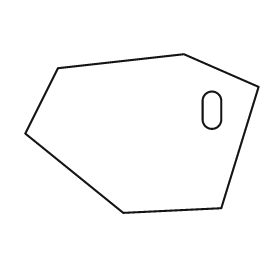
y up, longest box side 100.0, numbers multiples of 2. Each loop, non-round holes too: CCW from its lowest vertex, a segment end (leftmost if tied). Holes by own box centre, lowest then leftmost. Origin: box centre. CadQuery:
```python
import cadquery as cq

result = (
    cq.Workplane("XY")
    .moveTo(-8.0, -34.0)
    .lineTo(34.0, -32.0)
    .lineTo(50.0, 20.0)
    .lineTo(18.0, 34.0)
    .lineTo(-36.0, 28.0)
    .lineTo(-50.0, 0.0)
    .close()
    .moveTo(26.0, 6.0)
    .threePointArc((30.0, 2.0), (34.0, 6.0))
    .lineTo(34.0, 14.0)
    .threePointArc((30.0, 18.0), (26.0, 14.0))
    .close()
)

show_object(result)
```